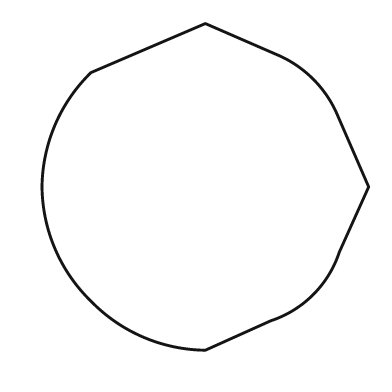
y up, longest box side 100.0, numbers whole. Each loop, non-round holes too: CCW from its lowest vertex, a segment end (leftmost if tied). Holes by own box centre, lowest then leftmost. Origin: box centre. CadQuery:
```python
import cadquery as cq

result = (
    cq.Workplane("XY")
    .moveTo(0.0, -50.0)
    .lineTo(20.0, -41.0)
    .threePointArc((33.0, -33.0), (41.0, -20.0))
    .lineTo(50.0, 0.0)
    .lineTo(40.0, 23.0)
    .threePointArc((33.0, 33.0), (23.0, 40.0))
    .lineTo(0.0, 50.0)
    .lineTo(-35.0, 35.0)
    .threePointArc((-46.0, 19.0), (-50.0, 0.0))
    .threePointArc((-46.0, -19.0), (-35.0, -35.0))
    .threePointArc((-19.0, -46.0), (0.0, -50.0))
    .close()
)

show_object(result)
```